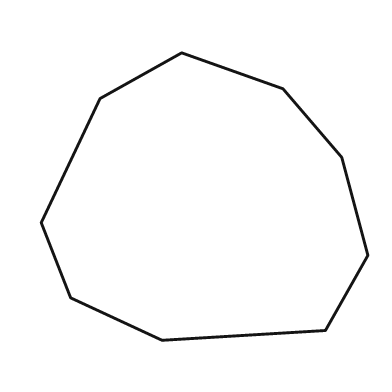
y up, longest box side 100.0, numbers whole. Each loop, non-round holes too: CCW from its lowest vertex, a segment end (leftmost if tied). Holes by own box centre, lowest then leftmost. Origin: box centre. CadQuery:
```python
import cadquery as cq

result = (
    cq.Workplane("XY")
    .moveTo(-13.0, -44.0)
    .lineTo(37.0, -41.0)
    .lineTo(50.0, -18.0)
    .lineTo(42.0, 12.0)
    .lineTo(24.0, 33.0)
    .lineTo(-7.0, 44.0)
    .lineTo(-32.0, 30.0)
    .lineTo(-50.0, -8.0)
    .lineTo(-41.0, -31.0)
    .close()
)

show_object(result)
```